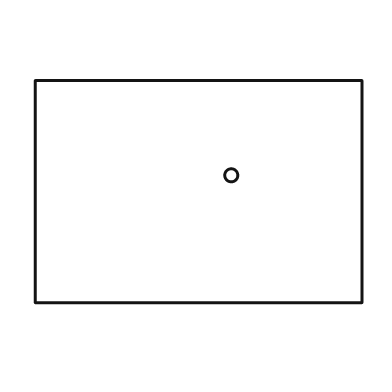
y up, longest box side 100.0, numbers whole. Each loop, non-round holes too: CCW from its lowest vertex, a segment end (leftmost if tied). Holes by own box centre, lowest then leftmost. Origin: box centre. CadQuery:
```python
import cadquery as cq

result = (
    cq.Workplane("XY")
    .moveTo(-50.0, -34.0)
    .lineTo(50.0, -34.0)
    .lineTo(50.0, 34.0)
    .lineTo(-50.0, 34.0)
    .close()
    .moveTo(10.0, 5.0)
    .circle(2.0)
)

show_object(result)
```